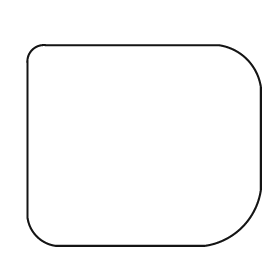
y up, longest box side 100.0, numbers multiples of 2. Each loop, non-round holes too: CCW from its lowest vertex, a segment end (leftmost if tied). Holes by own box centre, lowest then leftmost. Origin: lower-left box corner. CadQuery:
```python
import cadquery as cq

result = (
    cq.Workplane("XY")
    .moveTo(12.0, 0.0)
    .lineTo(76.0, 0.0)
    .threePointArc((92.0, 8.0), (100.0, 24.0))
    .lineTo(100.0, 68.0)
    .threePointArc((94.0, 80.0), (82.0, 86.0))
    .lineTo(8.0, 86.0)
    .threePointArc((2.0, 84.0), (0.0, 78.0))
    .lineTo(0.0, 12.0)
    .threePointArc((4.0, 4.0), (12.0, 0.0))
    .close()
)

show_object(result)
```